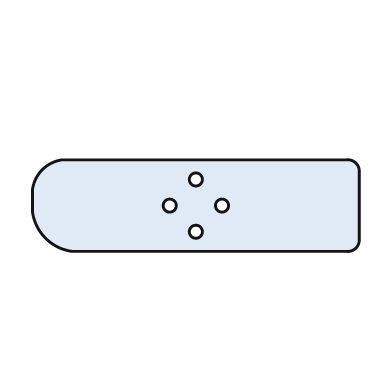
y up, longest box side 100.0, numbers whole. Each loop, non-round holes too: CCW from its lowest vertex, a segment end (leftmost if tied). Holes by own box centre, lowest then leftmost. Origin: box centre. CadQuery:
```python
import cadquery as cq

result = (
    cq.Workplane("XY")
    .moveTo(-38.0, -14.0)
    .lineTo(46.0, -14.0)
    .threePointArc((49.0, -13.0), (50.0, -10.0))
    .lineTo(50.0, 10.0)
    .threePointArc((49.0, 13.0), (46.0, 14.0))
    .lineTo(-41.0, 14.0)
    .threePointArc((-47.0, 11.0), (-50.0, 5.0))
    .lineTo(-50.0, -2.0)
    .threePointArc((-46.0, -10.0), (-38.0, -14.0))
    .close()
    .moveTo(0.0, -8.0)
    .circle(2.0)
    .moveTo(-8.0, 0.0)
    .circle(2.0)
    .moveTo(8.0, 0.0)
    .circle(2.0)
    .moveTo(0.0, 8.0)
    .circle(2.0)
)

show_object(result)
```